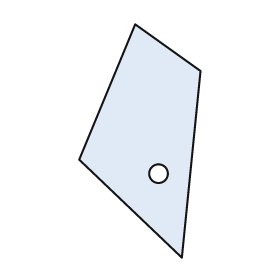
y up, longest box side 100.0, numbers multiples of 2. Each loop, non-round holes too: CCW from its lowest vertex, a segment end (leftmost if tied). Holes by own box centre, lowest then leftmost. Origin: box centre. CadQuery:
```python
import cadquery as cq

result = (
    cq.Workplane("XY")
    .moveTo(18.0, -50.0)
    .lineTo(26.0, 30.0)
    .lineTo(-2.0, 50.0)
    .lineTo(-26.0, -8.0)
    .close()
    .moveTo(8.0, -14.0)
    .circle(4.0)
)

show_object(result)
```